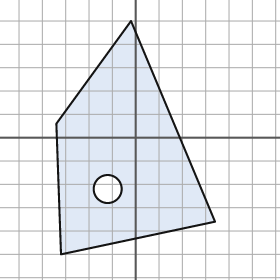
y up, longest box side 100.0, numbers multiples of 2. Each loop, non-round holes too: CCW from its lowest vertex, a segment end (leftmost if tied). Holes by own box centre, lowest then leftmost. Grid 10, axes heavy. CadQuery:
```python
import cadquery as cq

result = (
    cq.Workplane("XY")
    .moveTo(-32.0, -50.0)
    .lineTo(34.0, -36.0)
    .lineTo(-2.0, 50.0)
    .lineTo(-34.0, 6.0)
    .close()
    .moveTo(-12.0, -22.0)
    .circle(6.0)
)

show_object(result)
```